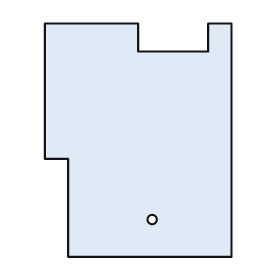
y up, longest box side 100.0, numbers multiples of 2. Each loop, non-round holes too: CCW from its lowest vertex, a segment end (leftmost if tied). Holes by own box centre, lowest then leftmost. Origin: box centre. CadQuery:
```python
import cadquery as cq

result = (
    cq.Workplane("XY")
    .moveTo(-30.0, -50.0)
    .lineTo(40.0, -50.0)
    .lineTo(40.0, 50.0)
    .lineTo(30.0, 50.0)
    .lineTo(30.0, 38.0)
    .lineTo(0.0, 38.0)
    .lineTo(0.0, 50.0)
    .lineTo(-40.0, 50.0)
    .lineTo(-40.0, -8.0)
    .lineTo(-30.0, -8.0)
    .close()
    .moveTo(6.0, -34.0)
    .circle(2.0)
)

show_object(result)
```